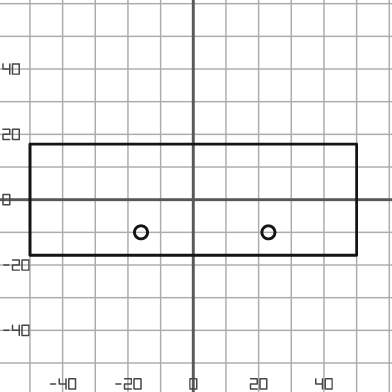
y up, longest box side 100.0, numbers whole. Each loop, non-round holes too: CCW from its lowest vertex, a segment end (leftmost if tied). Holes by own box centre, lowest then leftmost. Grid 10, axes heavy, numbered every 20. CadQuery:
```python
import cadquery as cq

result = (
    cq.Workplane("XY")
    .moveTo(-50.0, -17.0)
    .lineTo(50.0, -17.0)
    .lineTo(50.0, 17.0)
    .lineTo(-50.0, 17.0)
    .close()
    .moveTo(-16.0, -10.0)
    .circle(2.0)
    .moveTo(23.0, -10.0)
    .circle(2.0)
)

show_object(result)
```